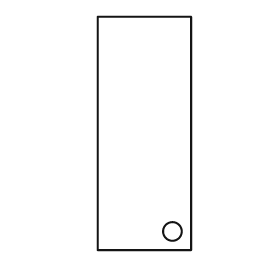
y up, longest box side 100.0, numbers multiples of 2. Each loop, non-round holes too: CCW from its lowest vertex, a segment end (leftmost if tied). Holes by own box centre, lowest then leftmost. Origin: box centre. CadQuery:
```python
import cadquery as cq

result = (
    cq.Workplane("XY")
    .moveTo(-20.0, -50.0)
    .lineTo(20.0, -50.0)
    .lineTo(20.0, 50.0)
    .lineTo(-20.0, 50.0)
    .close()
    .moveTo(12.0, -42.0)
    .circle(4.0)
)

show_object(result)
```